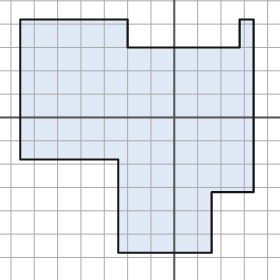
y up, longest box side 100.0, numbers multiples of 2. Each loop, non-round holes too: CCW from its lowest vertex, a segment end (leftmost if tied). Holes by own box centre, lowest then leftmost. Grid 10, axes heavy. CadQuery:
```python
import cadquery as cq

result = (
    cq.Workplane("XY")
    .moveTo(-24.0, -58.0)
    .lineTo(16.0, -58.0)
    .lineTo(16.0, -32.0)
    .lineTo(34.0, -32.0)
    .lineTo(34.0, 42.0)
    .lineTo(28.0, 42.0)
    .lineTo(28.0, 30.0)
    .lineTo(-20.0, 30.0)
    .lineTo(-20.0, 42.0)
    .lineTo(-66.0, 42.0)
    .lineTo(-66.0, -18.0)
    .lineTo(-24.0, -18.0)
    .close()
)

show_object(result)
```